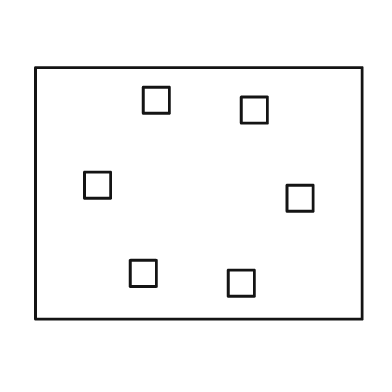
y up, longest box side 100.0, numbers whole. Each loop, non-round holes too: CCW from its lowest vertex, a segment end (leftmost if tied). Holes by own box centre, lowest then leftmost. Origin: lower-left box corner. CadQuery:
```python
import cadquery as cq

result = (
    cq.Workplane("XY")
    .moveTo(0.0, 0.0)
    .lineTo(100.0, 0.0)
    .lineTo(100.0, 77.0)
    .lineTo(0.0, 77.0)
    .close()
    .moveTo(59.0, 7.0)
    .lineTo(67.0, 7.0)
    .lineTo(67.0, 15.0)
    .lineTo(59.0, 15.0)
    .close()
    .moveTo(29.0, 10.0)
    .lineTo(37.0, 10.0)
    .lineTo(37.0, 18.0)
    .lineTo(29.0, 18.0)
    .close()
    .moveTo(77.0, 33.0)
    .lineTo(85.0, 33.0)
    .lineTo(85.0, 41.0)
    .lineTo(77.0, 41.0)
    .close()
    .moveTo(15.0, 37.0)
    .lineTo(23.0, 37.0)
    .lineTo(23.0, 45.0)
    .lineTo(15.0, 45.0)
    .close()
    .moveTo(63.0, 60.0)
    .lineTo(71.0, 60.0)
    .lineTo(71.0, 68.0)
    .lineTo(63.0, 68.0)
    .close()
    .moveTo(33.0, 63.0)
    .lineTo(41.0, 63.0)
    .lineTo(41.0, 71.0)
    .lineTo(33.0, 71.0)
    .close()
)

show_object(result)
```